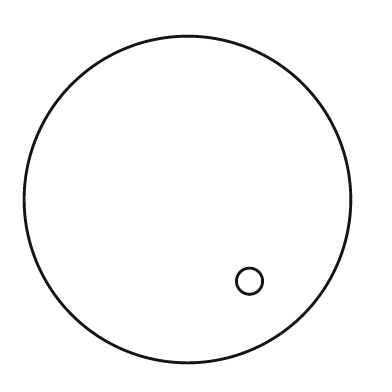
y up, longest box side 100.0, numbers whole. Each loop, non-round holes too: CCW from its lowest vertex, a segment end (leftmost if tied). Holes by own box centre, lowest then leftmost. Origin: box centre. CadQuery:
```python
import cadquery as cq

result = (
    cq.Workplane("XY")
    .moveTo(0.0, 0.0)
    .circle(50.0)
    .moveTo(19.0, -25.0)
    .circle(4.0)
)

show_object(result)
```